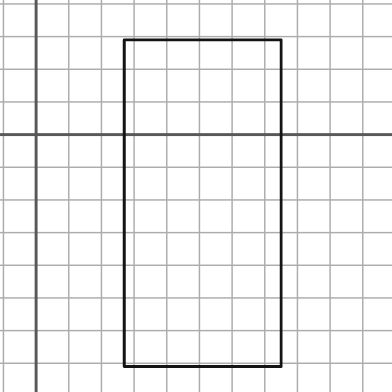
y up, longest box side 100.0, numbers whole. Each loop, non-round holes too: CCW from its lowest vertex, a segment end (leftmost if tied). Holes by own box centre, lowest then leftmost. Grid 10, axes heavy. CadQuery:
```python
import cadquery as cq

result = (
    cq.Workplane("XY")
    .moveTo(27.0, -71.0)
    .lineTo(75.0, -71.0)
    .lineTo(75.0, 29.0)
    .lineTo(27.0, 29.0)
    .close()
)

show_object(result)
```